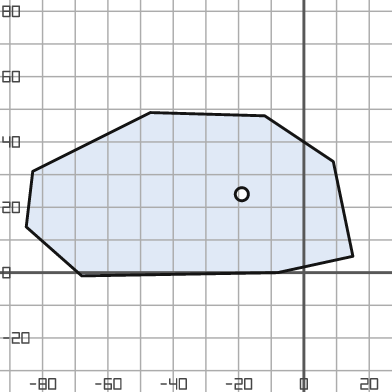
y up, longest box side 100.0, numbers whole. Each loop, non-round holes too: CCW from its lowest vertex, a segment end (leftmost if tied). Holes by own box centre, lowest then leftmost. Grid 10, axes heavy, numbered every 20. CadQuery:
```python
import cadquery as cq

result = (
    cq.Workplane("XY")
    .moveTo(-68.0, -1.0)
    .lineTo(-8.0, 0.0)
    .lineTo(15.0, 5.0)
    .lineTo(9.0, 34.0)
    .lineTo(-12.0, 48.0)
    .lineTo(-47.0, 49.0)
    .lineTo(-83.0, 31.0)
    .lineTo(-85.0, 14.0)
    .close()
    .moveTo(-19.0, 24.0)
    .circle(2.0)
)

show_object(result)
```